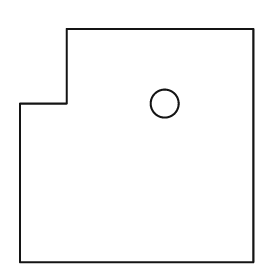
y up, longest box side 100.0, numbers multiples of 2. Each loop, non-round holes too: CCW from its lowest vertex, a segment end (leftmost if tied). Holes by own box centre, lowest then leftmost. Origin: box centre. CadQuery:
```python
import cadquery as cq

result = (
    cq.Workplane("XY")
    .moveTo(-50.0, -50.0)
    .lineTo(50.0, -50.0)
    .lineTo(50.0, 50.0)
    .lineTo(-30.0, 50.0)
    .lineTo(-30.0, 18.0)
    .lineTo(-50.0, 18.0)
    .close()
    .moveTo(12.0, 18.0)
    .circle(6.0)
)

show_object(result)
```